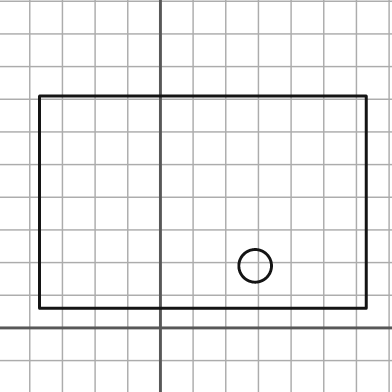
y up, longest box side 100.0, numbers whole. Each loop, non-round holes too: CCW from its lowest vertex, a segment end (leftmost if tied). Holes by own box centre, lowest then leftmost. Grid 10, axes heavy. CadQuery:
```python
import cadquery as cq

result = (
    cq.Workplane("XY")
    .moveTo(-37.0, 6.0)
    .lineTo(63.0, 6.0)
    .lineTo(63.0, 71.0)
    .lineTo(-37.0, 71.0)
    .close()
    .moveTo(29.0, 19.0)
    .circle(5.0)
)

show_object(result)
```